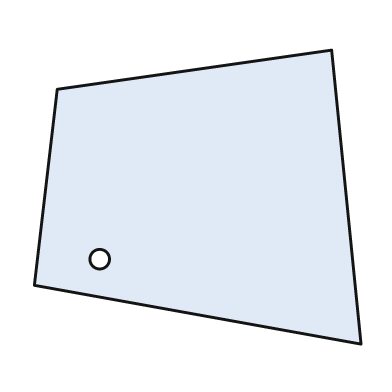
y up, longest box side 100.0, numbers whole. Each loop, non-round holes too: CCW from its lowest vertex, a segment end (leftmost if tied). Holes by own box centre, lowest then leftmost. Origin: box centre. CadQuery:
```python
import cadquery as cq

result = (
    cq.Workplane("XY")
    .moveTo(50.0, -45.0)
    .lineTo(41.0, 45.0)
    .lineTo(-43.0, 33.0)
    .lineTo(-50.0, -27.0)
    .close()
    .moveTo(-30.0, -19.0)
    .circle(3.0)
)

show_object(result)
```